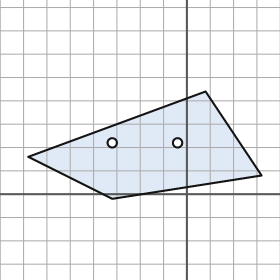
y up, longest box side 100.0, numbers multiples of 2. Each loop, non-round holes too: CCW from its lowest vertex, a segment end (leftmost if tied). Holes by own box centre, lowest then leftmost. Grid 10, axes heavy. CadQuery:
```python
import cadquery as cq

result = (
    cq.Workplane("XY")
    .moveTo(-32.0, -2.0)
    .lineTo(32.0, 8.0)
    .lineTo(8.0, 44.0)
    .lineTo(-68.0, 16.0)
    .close()
    .moveTo(-32.0, 22.0)
    .circle(2.0)
    .moveTo(-4.0, 22.0)
    .circle(2.0)
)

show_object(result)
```